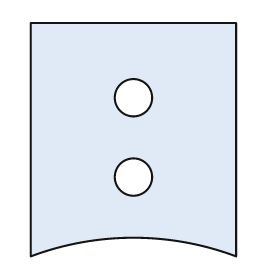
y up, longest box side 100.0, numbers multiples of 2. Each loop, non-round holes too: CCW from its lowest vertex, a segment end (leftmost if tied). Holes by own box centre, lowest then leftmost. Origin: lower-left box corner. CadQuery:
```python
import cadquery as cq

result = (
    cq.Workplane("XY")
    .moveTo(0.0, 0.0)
    .threePointArc((44.0, 8.0), (88.0, 0.0))
    .lineTo(88.0, 100.0)
    .lineTo(0.0, 100.0)
    .close()
    .moveTo(44.0, 34.0)
    .circle(8.0)
    .moveTo(44.0, 68.0)
    .circle(8.0)
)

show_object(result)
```